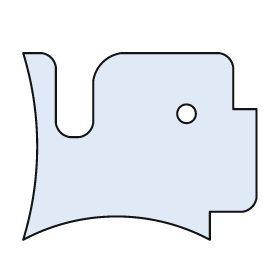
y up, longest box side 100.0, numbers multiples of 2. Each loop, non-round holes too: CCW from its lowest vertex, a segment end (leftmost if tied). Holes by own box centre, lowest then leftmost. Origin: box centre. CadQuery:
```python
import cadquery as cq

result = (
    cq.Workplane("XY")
    .moveTo(-50.0, -40.0)
    .threePointArc((-10.0, -30.0), (30.0, -40.0))
    .lineTo(30.0, -28.0)
    .lineTo(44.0, -28.0)
    .threePointArc((48.0, -26.0), (50.0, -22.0))
    .lineTo(50.0, 16.0)
    .lineTo(40.0, 16.0)
    .lineTo(40.0, 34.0)
    .threePointArc((38.0, 38.0), (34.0, 40.0))
    .lineTo(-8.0, 40.0)
    .threePointArc((-16.0, 36.0), (-20.0, 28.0))
    .lineTo(-20.0, 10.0)
    .threePointArc((-22.0, 6.0), (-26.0, 4.0))
    .lineTo(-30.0, 4.0)
    .threePointArc((-34.0, 6.0), (-36.0, 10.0))
    .lineTo(-36.0, 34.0)
    .threePointArc((-38.0, 38.0), (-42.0, 40.0))
    .lineTo(-50.0, 40.0)
    .threePointArc((-44.0, 0.0), (-50.0, -40.0))
    .close()
    .moveTo(20.0, 14.0)
    .circle(4.0)
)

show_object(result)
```